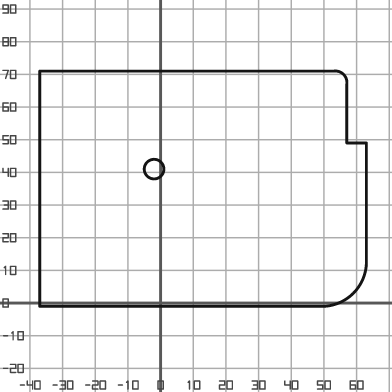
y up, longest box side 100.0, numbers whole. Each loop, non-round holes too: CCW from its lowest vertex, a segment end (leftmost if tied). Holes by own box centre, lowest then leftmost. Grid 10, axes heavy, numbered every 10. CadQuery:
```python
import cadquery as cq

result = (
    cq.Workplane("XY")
    .moveTo(-37.0, -1.0)
    .lineTo(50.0, -1.0)
    .threePointArc((59.0, 3.0), (63.0, 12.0))
    .lineTo(63.0, 49.0)
    .lineTo(57.0, 49.0)
    .lineTo(57.0, 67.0)
    .threePointArc((56.0, 70.0), (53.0, 71.0))
    .lineTo(-37.0, 71.0)
    .close()
    .moveTo(-2.0, 41.0)
    .circle(3.0)
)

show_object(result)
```